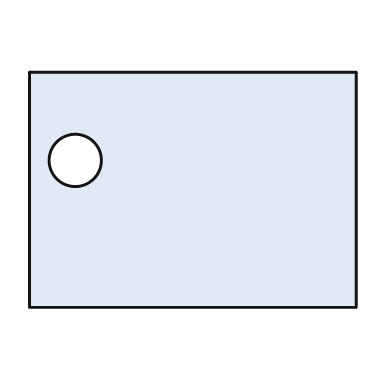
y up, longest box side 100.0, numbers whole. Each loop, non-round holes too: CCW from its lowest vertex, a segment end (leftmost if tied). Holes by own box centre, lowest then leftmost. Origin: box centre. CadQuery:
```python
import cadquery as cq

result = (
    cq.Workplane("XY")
    .moveTo(-50.0, -36.0)
    .lineTo(50.0, -36.0)
    .lineTo(50.0, 36.0)
    .lineTo(-50.0, 36.0)
    .close()
    .moveTo(-36.0, 9.0)
    .circle(8.0)
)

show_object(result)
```